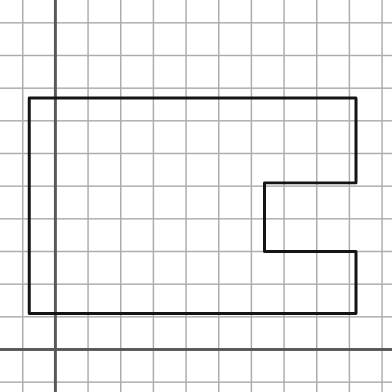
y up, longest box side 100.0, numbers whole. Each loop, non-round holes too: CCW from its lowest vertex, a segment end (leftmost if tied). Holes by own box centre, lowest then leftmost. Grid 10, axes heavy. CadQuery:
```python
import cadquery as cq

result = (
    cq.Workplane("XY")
    .moveTo(-8.0, 11.0)
    .lineTo(92.0, 11.0)
    .lineTo(92.0, 30.0)
    .lineTo(64.0, 30.0)
    .lineTo(64.0, 51.0)
    .lineTo(92.0, 51.0)
    .lineTo(92.0, 77.0)
    .lineTo(-8.0, 77.0)
    .close()
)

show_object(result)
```